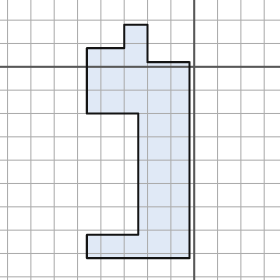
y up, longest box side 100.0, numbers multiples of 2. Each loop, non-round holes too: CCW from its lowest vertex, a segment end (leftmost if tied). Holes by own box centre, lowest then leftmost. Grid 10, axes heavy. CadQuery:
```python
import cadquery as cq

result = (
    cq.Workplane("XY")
    .moveTo(-46.0, -82.0)
    .lineTo(-2.0, -82.0)
    .lineTo(-2.0, 2.0)
    .lineTo(-20.0, 2.0)
    .lineTo(-20.0, 18.0)
    .lineTo(-30.0, 18.0)
    .lineTo(-30.0, 8.0)
    .lineTo(-46.0, 8.0)
    .lineTo(-46.0, -20.0)
    .lineTo(-24.0, -20.0)
    .lineTo(-24.0, -72.0)
    .lineTo(-46.0, -72.0)
    .close()
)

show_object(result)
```